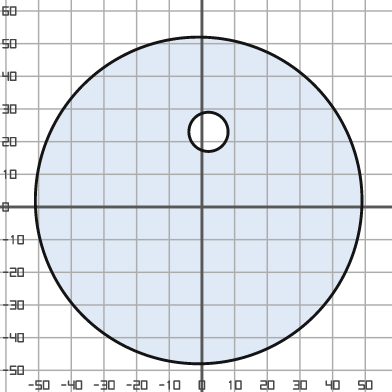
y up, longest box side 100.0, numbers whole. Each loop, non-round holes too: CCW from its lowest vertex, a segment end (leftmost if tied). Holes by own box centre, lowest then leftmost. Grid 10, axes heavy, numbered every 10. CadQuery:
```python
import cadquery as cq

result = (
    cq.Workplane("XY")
    .moveTo(-1.0, 2.0)
    .circle(50.0)
    .moveTo(2.0, 23.0)
    .circle(6.0)
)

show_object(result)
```